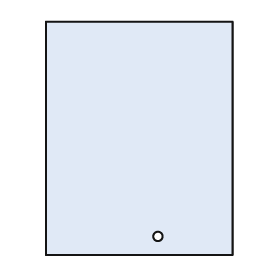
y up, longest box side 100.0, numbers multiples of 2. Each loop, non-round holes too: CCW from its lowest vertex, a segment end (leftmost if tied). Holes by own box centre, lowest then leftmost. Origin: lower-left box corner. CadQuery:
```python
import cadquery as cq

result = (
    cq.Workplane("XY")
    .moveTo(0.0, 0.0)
    .lineTo(80.0, 0.0)
    .lineTo(80.0, 100.0)
    .lineTo(0.0, 100.0)
    .close()
    .moveTo(48.0, 8.0)
    .circle(2.0)
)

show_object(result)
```